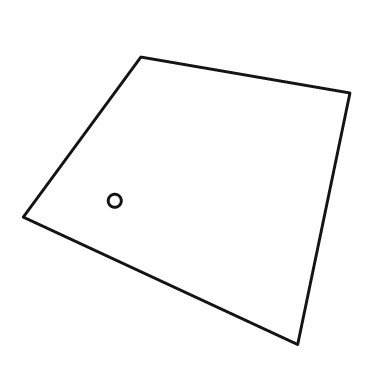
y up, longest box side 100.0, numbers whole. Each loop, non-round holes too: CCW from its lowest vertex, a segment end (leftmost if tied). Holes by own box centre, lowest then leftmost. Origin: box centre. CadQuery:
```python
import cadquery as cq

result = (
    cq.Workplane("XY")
    .moveTo(34.0, -44.0)
    .lineTo(50.0, 33.0)
    .lineTo(-14.0, 44.0)
    .lineTo(-50.0, -5.0)
    .close()
    .moveTo(-22.0, 0.0)
    .circle(2.0)
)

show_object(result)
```